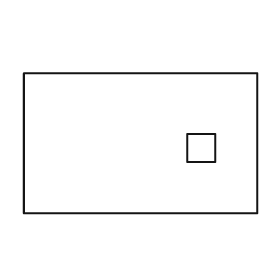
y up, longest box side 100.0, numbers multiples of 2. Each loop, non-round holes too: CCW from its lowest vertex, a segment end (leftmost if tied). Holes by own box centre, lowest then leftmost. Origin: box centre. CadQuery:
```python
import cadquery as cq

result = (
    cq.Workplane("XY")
    .moveTo(-50.0, -30.0)
    .lineTo(50.0, -30.0)
    .lineTo(50.0, 30.0)
    .lineTo(-50.0, 30.0)
    .close()
    .moveTo(20.0, -8.0)
    .lineTo(32.0, -8.0)
    .lineTo(32.0, 4.0)
    .lineTo(20.0, 4.0)
    .close()
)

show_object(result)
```